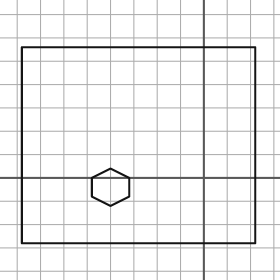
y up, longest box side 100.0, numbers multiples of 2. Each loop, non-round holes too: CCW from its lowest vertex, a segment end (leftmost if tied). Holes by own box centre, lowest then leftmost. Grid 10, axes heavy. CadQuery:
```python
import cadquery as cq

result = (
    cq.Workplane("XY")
    .moveTo(-78.0, -28.0)
    .lineTo(22.0, -28.0)
    .lineTo(22.0, 56.0)
    .lineTo(-78.0, 56.0)
    .close()
    .moveTo(-40.0, -12.0)
    .lineTo(-32.0, -8.0)
    .lineTo(-32.0, 0.0)
    .lineTo(-40.0, 4.0)
    .lineTo(-48.0, 0.0)
    .lineTo(-48.0, -8.0)
    .close()
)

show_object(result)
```